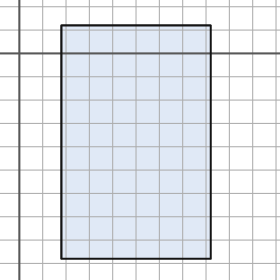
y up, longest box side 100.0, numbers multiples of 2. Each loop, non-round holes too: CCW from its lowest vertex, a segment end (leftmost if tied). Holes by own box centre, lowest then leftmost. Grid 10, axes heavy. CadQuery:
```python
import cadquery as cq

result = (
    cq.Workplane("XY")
    .moveTo(18.0, -88.0)
    .lineTo(82.0, -88.0)
    .lineTo(82.0, 12.0)
    .lineTo(18.0, 12.0)
    .close()
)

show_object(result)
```